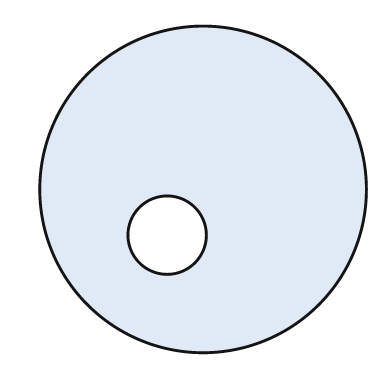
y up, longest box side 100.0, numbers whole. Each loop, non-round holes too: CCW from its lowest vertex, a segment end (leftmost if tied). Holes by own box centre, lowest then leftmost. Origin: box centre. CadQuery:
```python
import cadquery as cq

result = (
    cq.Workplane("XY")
    .moveTo(0.0, 0.0)
    .circle(50.0)
    .moveTo(-11.0, -14.0)
    .circle(12.0)
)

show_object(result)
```